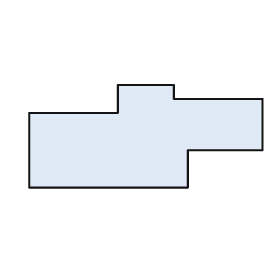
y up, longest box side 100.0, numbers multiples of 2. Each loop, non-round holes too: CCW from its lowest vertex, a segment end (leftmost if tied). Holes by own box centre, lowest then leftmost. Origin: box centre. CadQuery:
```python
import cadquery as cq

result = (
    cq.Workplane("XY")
    .moveTo(-50.0, -22.0)
    .lineTo(18.0, -22.0)
    .lineTo(18.0, -6.0)
    .lineTo(50.0, -6.0)
    .lineTo(50.0, 16.0)
    .lineTo(12.0, 16.0)
    .lineTo(12.0, 22.0)
    .lineTo(-12.0, 22.0)
    .lineTo(-12.0, 10.0)
    .lineTo(-50.0, 10.0)
    .close()
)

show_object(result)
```